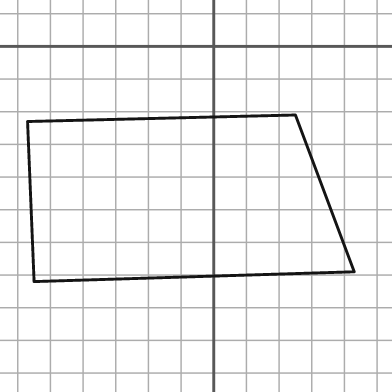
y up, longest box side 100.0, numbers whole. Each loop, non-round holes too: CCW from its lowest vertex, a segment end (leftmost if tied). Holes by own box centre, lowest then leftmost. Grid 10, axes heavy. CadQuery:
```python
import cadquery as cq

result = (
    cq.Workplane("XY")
    .moveTo(-55.0, -72.0)
    .lineTo(43.0, -69.0)
    .lineTo(25.0, -21.0)
    .lineTo(-57.0, -23.0)
    .close()
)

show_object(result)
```